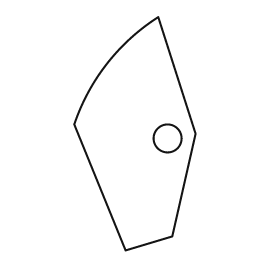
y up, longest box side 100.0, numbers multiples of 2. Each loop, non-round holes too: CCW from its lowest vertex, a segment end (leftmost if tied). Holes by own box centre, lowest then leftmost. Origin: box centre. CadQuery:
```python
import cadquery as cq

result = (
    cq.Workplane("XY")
    .moveTo(-4.0, -50.0)
    .lineTo(16.0, -44.0)
    .lineTo(26.0, 0.0)
    .lineTo(10.0, 50.0)
    .threePointArc((-12.0, 30.0), (-26.0, 4.0))
    .close()
    .moveTo(14.0, -2.0)
    .circle(6.0)
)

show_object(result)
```